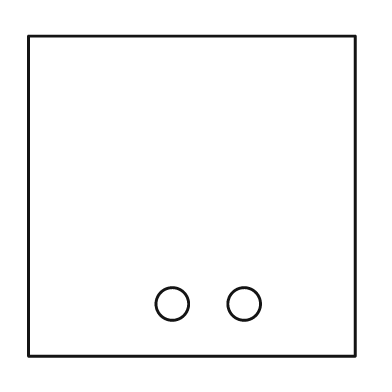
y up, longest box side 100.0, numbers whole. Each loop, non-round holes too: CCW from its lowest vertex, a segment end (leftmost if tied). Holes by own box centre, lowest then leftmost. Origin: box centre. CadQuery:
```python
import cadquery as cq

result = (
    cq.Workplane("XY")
    .moveTo(-50.0, -49.0)
    .lineTo(50.0, -49.0)
    .lineTo(50.0, 49.0)
    .lineTo(-50.0, 49.0)
    .close()
    .moveTo(-6.0, -33.0)
    .circle(5.0)
    .moveTo(16.0, -33.0)
    .circle(5.0)
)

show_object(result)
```